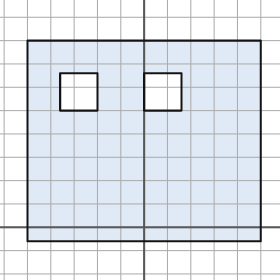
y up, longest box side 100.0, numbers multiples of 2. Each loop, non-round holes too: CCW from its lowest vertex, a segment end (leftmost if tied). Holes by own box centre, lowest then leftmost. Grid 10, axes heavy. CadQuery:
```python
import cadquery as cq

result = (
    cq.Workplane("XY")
    .moveTo(-50.0, -6.0)
    .lineTo(50.0, -6.0)
    .lineTo(50.0, 80.0)
    .lineTo(-50.0, 80.0)
    .close()
    .moveTo(-36.0, 50.0)
    .lineTo(-20.0, 50.0)
    .lineTo(-20.0, 66.0)
    .lineTo(-36.0, 66.0)
    .close()
    .moveTo(0.0, 50.0)
    .lineTo(16.0, 50.0)
    .lineTo(16.0, 66.0)
    .lineTo(0.0, 66.0)
    .close()
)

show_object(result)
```